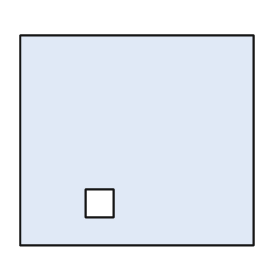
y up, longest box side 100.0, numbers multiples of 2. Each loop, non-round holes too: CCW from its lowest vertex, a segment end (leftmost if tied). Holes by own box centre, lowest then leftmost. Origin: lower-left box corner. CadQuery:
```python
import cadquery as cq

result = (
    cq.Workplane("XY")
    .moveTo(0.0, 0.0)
    .lineTo(100.0, 0.0)
    .lineTo(100.0, 90.0)
    .lineTo(0.0, 90.0)
    .close()
    .moveTo(28.0, 12.0)
    .lineTo(40.0, 12.0)
    .lineTo(40.0, 24.0)
    .lineTo(28.0, 24.0)
    .close()
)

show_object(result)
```